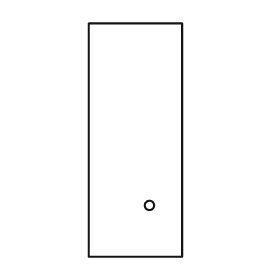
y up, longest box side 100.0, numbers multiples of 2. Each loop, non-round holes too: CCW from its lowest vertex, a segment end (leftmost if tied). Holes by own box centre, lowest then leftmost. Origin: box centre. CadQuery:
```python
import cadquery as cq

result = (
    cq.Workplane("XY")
    .moveTo(-20.0, -50.0)
    .lineTo(20.0, -50.0)
    .lineTo(20.0, 50.0)
    .lineTo(-20.0, 50.0)
    .close()
    .moveTo(6.0, -28.0)
    .circle(2.0)
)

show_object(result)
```